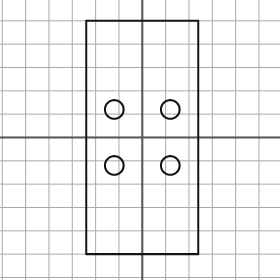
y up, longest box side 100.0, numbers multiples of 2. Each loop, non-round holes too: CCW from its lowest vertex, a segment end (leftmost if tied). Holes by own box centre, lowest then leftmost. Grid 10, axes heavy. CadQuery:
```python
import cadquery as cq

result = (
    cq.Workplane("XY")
    .moveTo(-24.0, -50.0)
    .lineTo(24.0, -50.0)
    .lineTo(24.0, 50.0)
    .lineTo(-24.0, 50.0)
    .close()
    .moveTo(-12.0, -12.0)
    .circle(4.0)
    .moveTo(12.0, -12.0)
    .circle(4.0)
    .moveTo(-12.0, 12.0)
    .circle(4.0)
    .moveTo(12.0, 12.0)
    .circle(4.0)
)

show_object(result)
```